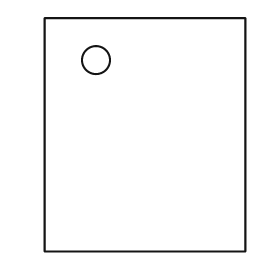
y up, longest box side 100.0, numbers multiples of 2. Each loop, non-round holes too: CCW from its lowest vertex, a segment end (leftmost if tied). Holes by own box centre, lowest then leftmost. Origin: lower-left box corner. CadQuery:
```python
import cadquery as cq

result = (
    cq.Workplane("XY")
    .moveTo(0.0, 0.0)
    .lineTo(86.0, 0.0)
    .lineTo(86.0, 100.0)
    .lineTo(0.0, 100.0)
    .close()
    .moveTo(22.0, 82.0)
    .circle(6.0)
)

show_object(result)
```